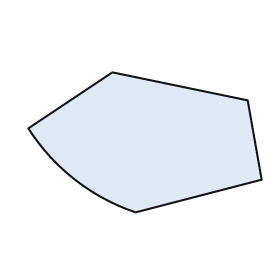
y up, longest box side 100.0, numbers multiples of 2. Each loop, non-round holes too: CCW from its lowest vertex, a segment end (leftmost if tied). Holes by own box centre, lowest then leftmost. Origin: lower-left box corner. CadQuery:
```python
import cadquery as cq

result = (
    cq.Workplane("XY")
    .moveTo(46.0, 0.0)
    .lineTo(100.0, 14.0)
    .lineTo(94.0, 48.0)
    .lineTo(36.0, 60.0)
    .lineTo(0.0, 36.0)
    .threePointArc((20.0, 14.0), (46.0, 0.0))
    .close()
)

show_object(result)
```